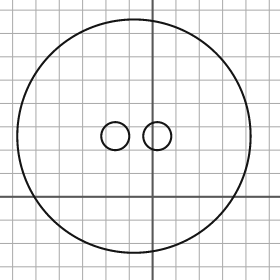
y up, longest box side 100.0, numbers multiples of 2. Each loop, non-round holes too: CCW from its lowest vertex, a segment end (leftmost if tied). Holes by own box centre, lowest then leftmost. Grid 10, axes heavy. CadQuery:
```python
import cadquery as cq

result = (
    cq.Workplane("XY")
    .moveTo(-8.0, 26.0)
    .circle(50.0)
    .moveTo(-16.0, 26.0)
    .circle(6.0)
    .moveTo(2.0, 26.0)
    .circle(6.0)
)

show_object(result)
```